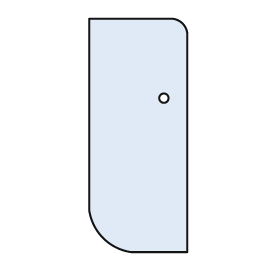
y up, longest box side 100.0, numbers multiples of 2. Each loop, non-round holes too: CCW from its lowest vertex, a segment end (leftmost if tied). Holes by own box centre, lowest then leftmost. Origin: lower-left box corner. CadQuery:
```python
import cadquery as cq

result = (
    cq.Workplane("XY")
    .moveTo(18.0, 0.0)
    .lineTo(42.0, 0.0)
    .lineTo(42.0, 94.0)
    .threePointArc((40.0, 98.0), (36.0, 100.0))
    .lineTo(0.0, 100.0)
    .lineTo(0.0, 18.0)
    .threePointArc((6.0, 6.0), (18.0, 0.0))
    .close()
    .moveTo(32.0, 66.0)
    .circle(2.0)
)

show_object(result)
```